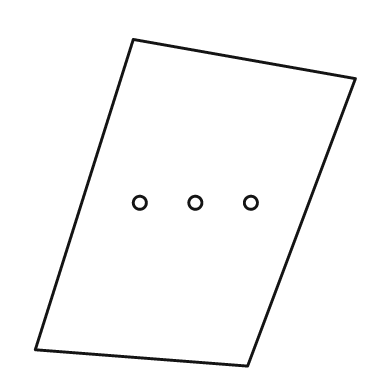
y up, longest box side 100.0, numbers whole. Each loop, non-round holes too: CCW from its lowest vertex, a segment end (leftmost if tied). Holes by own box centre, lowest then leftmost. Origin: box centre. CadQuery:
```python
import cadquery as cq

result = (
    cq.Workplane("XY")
    .moveTo(16.0, -50.0)
    .lineTo(49.0, 38.0)
    .lineTo(-19.0, 50.0)
    .lineTo(-49.0, -45.0)
    .close()
    .moveTo(-17.0, 0.0)
    .circle(2.0)
    .moveTo(0.0, 0.0)
    .circle(2.0)
    .moveTo(17.0, 0.0)
    .circle(2.0)
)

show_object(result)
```